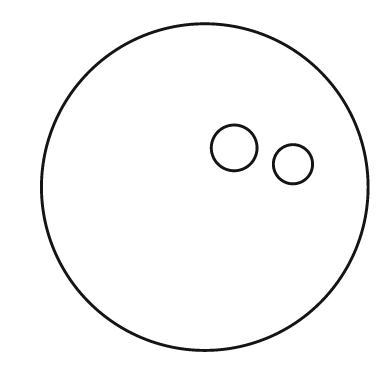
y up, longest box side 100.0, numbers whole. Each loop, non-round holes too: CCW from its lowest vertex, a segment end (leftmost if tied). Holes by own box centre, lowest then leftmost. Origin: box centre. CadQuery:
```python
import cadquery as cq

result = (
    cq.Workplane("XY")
    .moveTo(0.0, 0.0)
    .circle(50.0)
    .moveTo(27.0, 7.0)
    .circle(6.0)
    .moveTo(9.0, 12.0)
    .circle(7.0)
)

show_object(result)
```